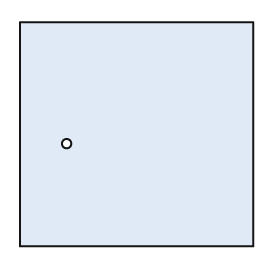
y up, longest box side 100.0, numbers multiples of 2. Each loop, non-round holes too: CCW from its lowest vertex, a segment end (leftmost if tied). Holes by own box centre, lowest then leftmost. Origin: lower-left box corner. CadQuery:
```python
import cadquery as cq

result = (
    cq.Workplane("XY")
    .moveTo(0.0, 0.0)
    .lineTo(100.0, 0.0)
    .lineTo(100.0, 96.0)
    .lineTo(0.0, 96.0)
    .close()
    .moveTo(20.0, 44.0)
    .circle(2.0)
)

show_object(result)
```